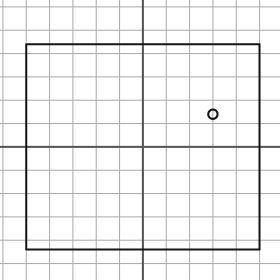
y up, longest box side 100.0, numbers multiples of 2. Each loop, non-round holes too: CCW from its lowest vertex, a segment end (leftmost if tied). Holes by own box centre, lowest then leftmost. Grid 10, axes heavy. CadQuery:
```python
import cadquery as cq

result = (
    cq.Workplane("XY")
    .moveTo(-50.0, -44.0)
    .lineTo(50.0, -44.0)
    .lineTo(50.0, 44.0)
    .lineTo(-50.0, 44.0)
    .close()
    .moveTo(30.0, 14.0)
    .circle(2.0)
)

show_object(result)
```